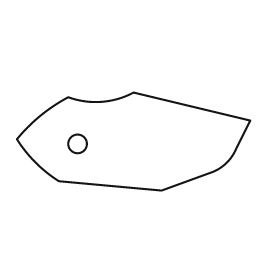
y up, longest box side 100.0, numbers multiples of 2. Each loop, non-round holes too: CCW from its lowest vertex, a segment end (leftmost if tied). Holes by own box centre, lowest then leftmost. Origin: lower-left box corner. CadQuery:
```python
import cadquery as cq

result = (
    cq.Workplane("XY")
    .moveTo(62.0, 0.0)
    .lineTo(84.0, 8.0)
    .threePointArc((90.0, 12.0), (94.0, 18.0))
    .lineTo(100.0, 30.0)
    .lineTo(50.0, 42.0)
    .threePointArc((36.0, 38.0), (22.0, 40.0))
    .threePointArc((10.0, 32.0), (0.0, 22.0))
    .threePointArc((8.0, 12.0), (18.0, 4.0))
    .close()
    .moveTo(26.0, 20.0)
    .circle(4.0)
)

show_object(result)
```